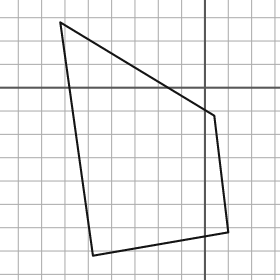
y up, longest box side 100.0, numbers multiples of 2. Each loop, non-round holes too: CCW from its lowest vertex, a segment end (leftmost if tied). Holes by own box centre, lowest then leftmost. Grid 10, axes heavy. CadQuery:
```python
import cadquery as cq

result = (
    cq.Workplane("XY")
    .moveTo(-48.0, -72.0)
    .lineTo(10.0, -62.0)
    .lineTo(4.0, -12.0)
    .lineTo(-62.0, 28.0)
    .close()
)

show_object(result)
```